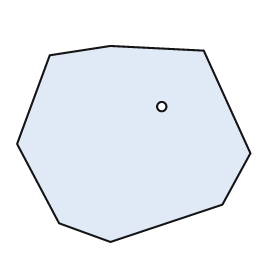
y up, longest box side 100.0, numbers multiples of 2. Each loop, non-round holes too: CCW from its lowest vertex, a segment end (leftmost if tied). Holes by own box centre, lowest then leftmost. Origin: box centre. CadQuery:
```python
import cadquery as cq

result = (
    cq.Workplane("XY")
    .moveTo(-10.0, -42.0)
    .lineTo(38.0, -26.0)
    .lineTo(50.0, -4.0)
    .lineTo(30.0, 40.0)
    .lineTo(-10.0, 42.0)
    .lineTo(-36.0, 38.0)
    .lineTo(-50.0, 0.0)
    .lineTo(-32.0, -34.0)
    .close()
    .moveTo(12.0, 16.0)
    .circle(2.0)
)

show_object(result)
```